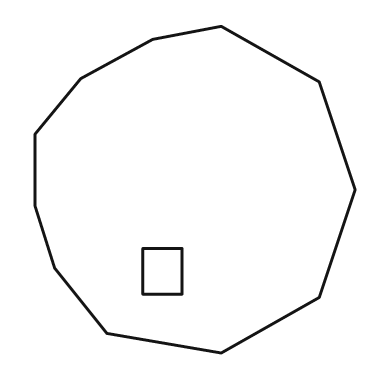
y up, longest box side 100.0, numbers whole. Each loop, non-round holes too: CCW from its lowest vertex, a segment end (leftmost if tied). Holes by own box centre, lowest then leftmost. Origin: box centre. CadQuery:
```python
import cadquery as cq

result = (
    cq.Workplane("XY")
    .moveTo(8.0, -50.0)
    .lineTo(38.0, -33.0)
    .lineTo(49.0, 0.0)
    .lineTo(38.0, 33.0)
    .lineTo(8.0, 50.0)
    .lineTo(-13.0, 46.0)
    .lineTo(-35.0, 34.0)
    .lineTo(-49.0, 17.0)
    .lineTo(-49.0, -5.0)
    .lineTo(-43.0, -24.0)
    .lineTo(-27.0, -44.0)
    .close()
    .moveTo(-16.0, -32.0)
    .lineTo(-4.0, -32.0)
    .lineTo(-4.0, -18.0)
    .lineTo(-16.0, -18.0)
    .close()
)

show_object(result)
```